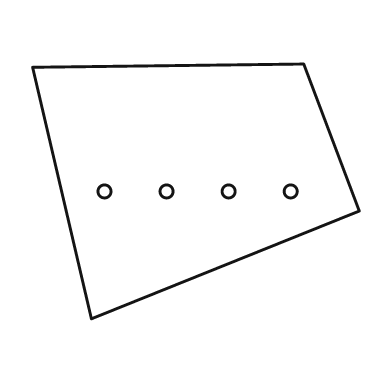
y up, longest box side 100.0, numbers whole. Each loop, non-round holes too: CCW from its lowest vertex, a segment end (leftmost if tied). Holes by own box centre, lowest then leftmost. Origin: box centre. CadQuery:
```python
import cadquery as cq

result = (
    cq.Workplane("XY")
    .moveTo(-32.0, -39.0)
    .lineTo(50.0, -6.0)
    .lineTo(33.0, 39.0)
    .lineTo(-50.0, 38.0)
    .close()
    .moveTo(-28.0, 0.0)
    .circle(2.0)
    .moveTo(-9.0, 0.0)
    .circle(2.0)
    .moveTo(10.0, 0.0)
    .circle(2.0)
    .moveTo(29.0, 0.0)
    .circle(2.0)
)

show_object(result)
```